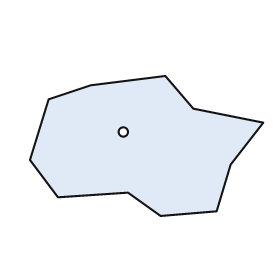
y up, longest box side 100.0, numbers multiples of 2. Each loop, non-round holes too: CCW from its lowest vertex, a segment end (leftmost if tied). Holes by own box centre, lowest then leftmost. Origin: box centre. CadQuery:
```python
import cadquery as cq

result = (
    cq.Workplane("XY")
    .moveTo(6.0, -30.0)
    .lineTo(30.0, -28.0)
    .lineTo(36.0, -8.0)
    .lineTo(50.0, 10.0)
    .lineTo(20.0, 16.0)
    .lineTo(8.0, 30.0)
    .lineTo(-24.0, 26.0)
    .lineTo(-42.0, 20.0)
    .lineTo(-50.0, -6.0)
    .lineTo(-38.0, -22.0)
    .lineTo(-8.0, -20.0)
    .close()
    .moveTo(-10.0, 6.0)
    .circle(2.0)
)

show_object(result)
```